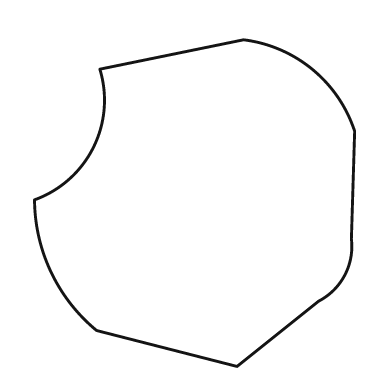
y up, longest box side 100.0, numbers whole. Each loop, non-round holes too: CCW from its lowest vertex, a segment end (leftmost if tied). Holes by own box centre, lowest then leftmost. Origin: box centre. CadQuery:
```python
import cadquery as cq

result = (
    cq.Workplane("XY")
    .moveTo(13.0, -50.0)
    .lineTo(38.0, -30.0)
    .threePointArc((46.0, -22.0), (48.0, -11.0))
    .lineTo(49.0, 22.0)
    .threePointArc((36.0, 41.0), (15.0, 50.0))
    .lineTo(-29.0, 41.0)
    .threePointArc((-31.0, 17.0), (-49.0, 1.0))
    .threePointArc((-44.0, -21.0), (-30.0, -39.0))
    .close()
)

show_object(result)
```